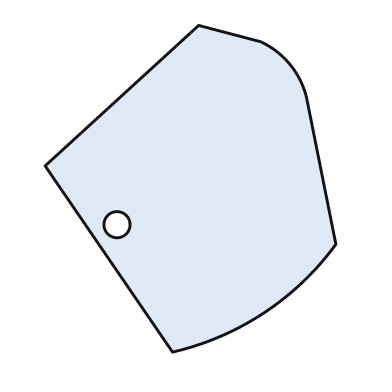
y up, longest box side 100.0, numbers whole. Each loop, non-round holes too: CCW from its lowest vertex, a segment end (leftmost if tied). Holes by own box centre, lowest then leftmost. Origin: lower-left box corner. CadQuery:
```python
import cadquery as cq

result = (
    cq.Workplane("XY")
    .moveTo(39.0, 0.0)
    .threePointArc((67.0, 12.0), (89.0, 33.0))
    .lineTo(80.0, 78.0)
    .threePointArc((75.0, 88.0), (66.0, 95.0))
    .lineTo(47.0, 100.0)
    .lineTo(0.0, 57.0)
    .close()
    .moveTo(22.0, 39.0)
    .circle(4.0)
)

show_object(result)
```